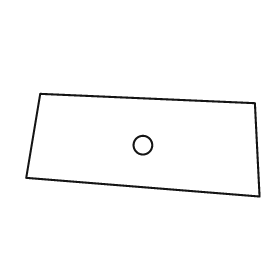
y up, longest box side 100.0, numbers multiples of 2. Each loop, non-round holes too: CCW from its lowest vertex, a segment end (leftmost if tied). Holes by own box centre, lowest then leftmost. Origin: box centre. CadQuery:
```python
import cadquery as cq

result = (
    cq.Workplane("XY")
    .moveTo(50.0, -22.0)
    .lineTo(48.0, 18.0)
    .lineTo(-44.0, 22.0)
    .lineTo(-50.0, -14.0)
    .close()
    .moveTo(0.0, 0.0)
    .circle(4.0)
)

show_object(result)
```